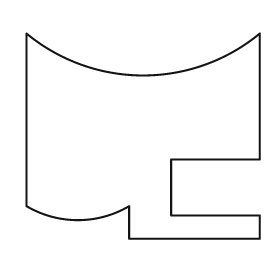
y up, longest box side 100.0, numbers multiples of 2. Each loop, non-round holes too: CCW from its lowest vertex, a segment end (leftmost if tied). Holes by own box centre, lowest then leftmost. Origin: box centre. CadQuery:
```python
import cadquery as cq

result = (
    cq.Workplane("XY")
    .moveTo(-6.0, -44.0)
    .lineTo(50.0, -44.0)
    .lineTo(50.0, -34.0)
    .lineTo(12.0, -34.0)
    .lineTo(12.0, -10.0)
    .lineTo(50.0, -10.0)
    .lineTo(50.0, 44.0)
    .threePointArc((0.0, 26.0), (-50.0, 44.0))
    .lineTo(-50.0, -30.0)
    .threePointArc((-28.0, -36.0), (-6.0, -30.0))
    .close()
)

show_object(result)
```